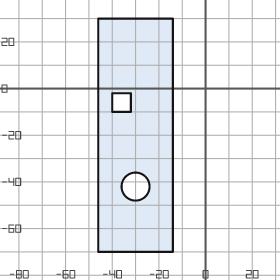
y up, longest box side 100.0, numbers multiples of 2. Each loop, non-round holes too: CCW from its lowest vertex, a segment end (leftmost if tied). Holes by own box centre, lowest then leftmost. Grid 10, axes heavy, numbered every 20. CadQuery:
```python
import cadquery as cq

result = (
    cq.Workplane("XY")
    .moveTo(-46.0, -70.0)
    .lineTo(-14.0, -70.0)
    .lineTo(-14.0, 30.0)
    .lineTo(-46.0, 30.0)
    .close()
    .moveTo(-30.0, -42.0)
    .circle(6.0)
    .moveTo(-40.0, -10.0)
    .lineTo(-32.0, -10.0)
    .lineTo(-32.0, -2.0)
    .lineTo(-40.0, -2.0)
    .close()
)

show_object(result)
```